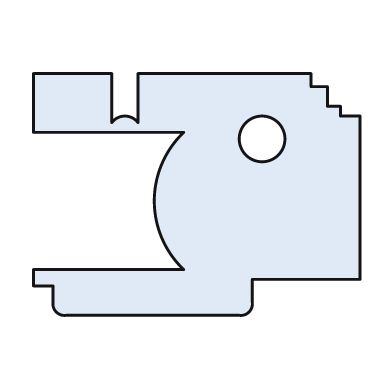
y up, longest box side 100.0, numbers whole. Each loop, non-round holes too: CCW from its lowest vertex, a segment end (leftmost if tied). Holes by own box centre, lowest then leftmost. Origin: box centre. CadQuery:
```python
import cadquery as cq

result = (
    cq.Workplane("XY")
    .moveTo(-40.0, -37.0)
    .lineTo(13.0, -37.0)
    .threePointArc((16.0, -36.0), (17.0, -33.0))
    .lineTo(17.0, -26.0)
    .lineTo(50.0, -26.0)
    .lineTo(50.0, 24.0)
    .lineTo(44.0, 24.0)
    .lineTo(44.0, 27.0)
    .lineTo(40.0, 27.0)
    .lineTo(40.0, 33.0)
    .lineTo(35.0, 33.0)
    .lineTo(35.0, 37.0)
    .lineTo(-18.0, 37.0)
    .lineTo(-18.0, 22.0)
    .threePointArc((-22.0, 24.0), (-26.0, 22.0))
    .lineTo(-26.0, 37.0)
    .lineTo(-50.0, 37.0)
    .lineTo(-50.0, 19.0)
    .lineTo(-4.0, 19.0)
    .threePointArc((-13.0, -2.0), (-4.0, -23.0))
    .lineTo(-50.0, -23.0)
    .lineTo(-50.0, -28.0)
    .lineTo(-44.0, -28.0)
    .lineTo(-44.0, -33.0)
    .threePointArc((-43.0, -36.0), (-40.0, -37.0))
    .close()
    .moveTo(20.0, 17.0)
    .circle(7.0)
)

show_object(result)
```